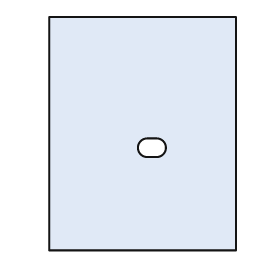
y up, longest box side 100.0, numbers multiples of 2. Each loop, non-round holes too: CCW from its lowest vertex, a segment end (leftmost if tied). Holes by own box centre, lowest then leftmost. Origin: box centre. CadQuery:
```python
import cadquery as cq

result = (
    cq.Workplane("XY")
    .moveTo(-40.0, -50.0)
    .lineTo(40.0, -50.0)
    .lineTo(40.0, 50.0)
    .lineTo(-40.0, 50.0)
    .close()
    .moveTo(2.0, -10.0)
    .lineTo(6.0, -10.0)
    .threePointArc((10.0, -6.0), (6.0, -2.0))
    .lineTo(2.0, -2.0)
    .threePointArc((-2.0, -6.0), (2.0, -10.0))
    .close()
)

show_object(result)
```